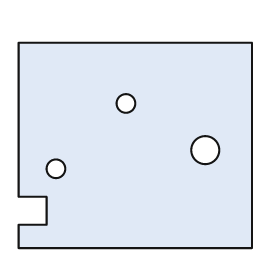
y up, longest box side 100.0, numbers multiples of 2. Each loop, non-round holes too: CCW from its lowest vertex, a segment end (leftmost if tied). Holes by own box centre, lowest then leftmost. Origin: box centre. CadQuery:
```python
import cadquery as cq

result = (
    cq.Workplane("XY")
    .moveTo(-50.0, -44.0)
    .lineTo(50.0, -44.0)
    .lineTo(50.0, 44.0)
    .lineTo(-50.0, 44.0)
    .lineTo(-50.0, -22.0)
    .lineTo(-38.0, -22.0)
    .lineTo(-38.0, -34.0)
    .lineTo(-50.0, -34.0)
    .close()
    .moveTo(-34.0, -10.0)
    .circle(4.0)
    .moveTo(30.0, -2.0)
    .circle(6.0)
    .moveTo(-4.0, 18.0)
    .circle(4.0)
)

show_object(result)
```